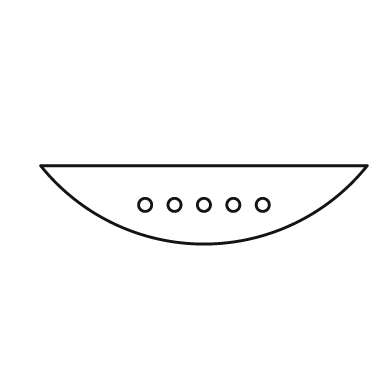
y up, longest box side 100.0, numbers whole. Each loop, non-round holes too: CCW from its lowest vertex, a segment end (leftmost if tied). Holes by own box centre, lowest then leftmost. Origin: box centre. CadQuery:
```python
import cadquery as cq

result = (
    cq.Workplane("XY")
    .moveTo(-50.0, 12.0)
    .threePointArc((0.0, -12.0), (50.0, 12.0))
    .close()
    .moveTo(-18.0, 0.0)
    .circle(2.0)
    .moveTo(-9.0, 0.0)
    .circle(2.0)
    .moveTo(0.0, 0.0)
    .circle(2.0)
    .moveTo(9.0, 0.0)
    .circle(2.0)
    .moveTo(18.0, 0.0)
    .circle(2.0)
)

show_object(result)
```